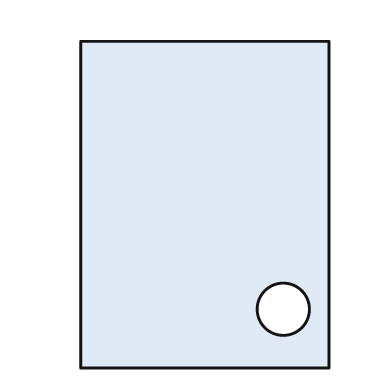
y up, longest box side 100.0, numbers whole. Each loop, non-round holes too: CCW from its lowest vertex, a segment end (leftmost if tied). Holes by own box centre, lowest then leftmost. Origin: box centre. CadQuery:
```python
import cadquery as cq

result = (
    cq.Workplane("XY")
    .moveTo(-38.0, -50.0)
    .lineTo(38.0, -50.0)
    .lineTo(38.0, 50.0)
    .lineTo(-38.0, 50.0)
    .close()
    .moveTo(24.0, -32.0)
    .circle(8.0)
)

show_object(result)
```